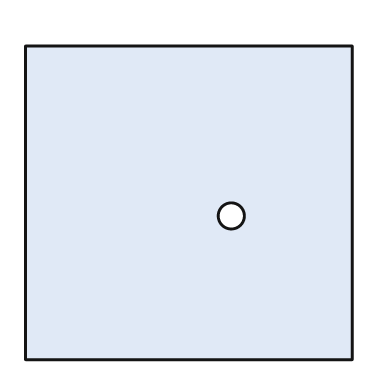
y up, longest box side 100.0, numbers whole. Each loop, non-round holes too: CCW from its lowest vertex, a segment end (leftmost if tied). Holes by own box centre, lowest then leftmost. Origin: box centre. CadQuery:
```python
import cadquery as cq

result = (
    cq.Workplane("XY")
    .moveTo(-50.0, -48.0)
    .lineTo(50.0, -48.0)
    .lineTo(50.0, 48.0)
    .lineTo(-50.0, 48.0)
    .close()
    .moveTo(13.0, -4.0)
    .circle(4.0)
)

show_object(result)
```